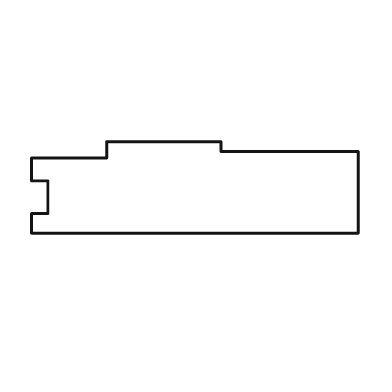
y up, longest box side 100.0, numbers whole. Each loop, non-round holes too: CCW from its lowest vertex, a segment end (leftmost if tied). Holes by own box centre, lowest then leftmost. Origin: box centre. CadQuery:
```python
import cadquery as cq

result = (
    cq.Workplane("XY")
    .moveTo(-50.0, -14.0)
    .lineTo(50.0, -14.0)
    .lineTo(50.0, 11.0)
    .lineTo(8.0, 11.0)
    .lineTo(8.0, 14.0)
    .lineTo(-27.0, 14.0)
    .lineTo(-27.0, 9.0)
    .lineTo(-50.0, 9.0)
    .lineTo(-50.0, 2.0)
    .lineTo(-45.0, 2.0)
    .lineTo(-45.0, -8.0)
    .lineTo(-50.0, -8.0)
    .close()
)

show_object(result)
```